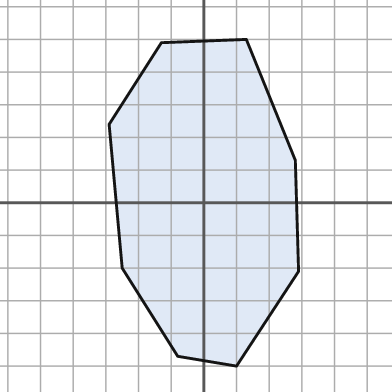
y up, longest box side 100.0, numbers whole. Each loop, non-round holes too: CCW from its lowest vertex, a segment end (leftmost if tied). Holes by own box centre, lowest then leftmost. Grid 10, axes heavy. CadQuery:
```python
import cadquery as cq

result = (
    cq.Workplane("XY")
    .moveTo(10.0, -50.0)
    .lineTo(29.0, -21.0)
    .lineTo(28.0, 13.0)
    .lineTo(13.0, 50.0)
    .lineTo(-13.0, 49.0)
    .lineTo(-29.0, 24.0)
    .lineTo(-25.0, -20.0)
    .lineTo(-8.0, -47.0)
    .close()
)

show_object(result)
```